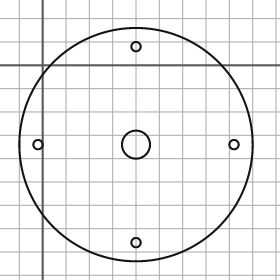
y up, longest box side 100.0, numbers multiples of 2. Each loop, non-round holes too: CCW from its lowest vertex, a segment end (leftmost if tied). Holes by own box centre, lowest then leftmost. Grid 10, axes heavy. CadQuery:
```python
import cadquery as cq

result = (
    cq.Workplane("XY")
    .moveTo(40.0, -34.0)
    .circle(50.0)
    .moveTo(40.0, -76.0)
    .circle(2.0)
    .moveTo(-2.0, -34.0)
    .circle(2.0)
    .moveTo(40.0, -34.0)
    .circle(6.0)
    .moveTo(82.0, -34.0)
    .circle(2.0)
    .moveTo(40.0, 8.0)
    .circle(2.0)
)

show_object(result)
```